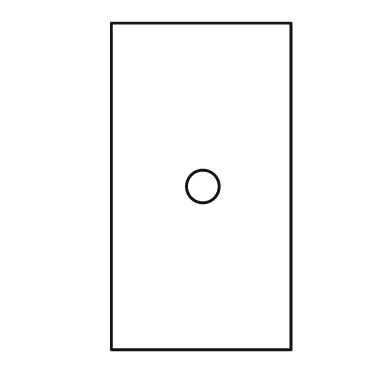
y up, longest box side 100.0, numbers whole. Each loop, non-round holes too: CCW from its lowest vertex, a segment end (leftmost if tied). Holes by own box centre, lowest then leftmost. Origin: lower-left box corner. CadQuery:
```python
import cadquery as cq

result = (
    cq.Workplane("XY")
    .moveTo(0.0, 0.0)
    .lineTo(55.0, 0.0)
    .lineTo(55.0, 100.0)
    .lineTo(0.0, 100.0)
    .close()
    .moveTo(28.0, 50.0)
    .circle(5.0)
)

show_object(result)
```